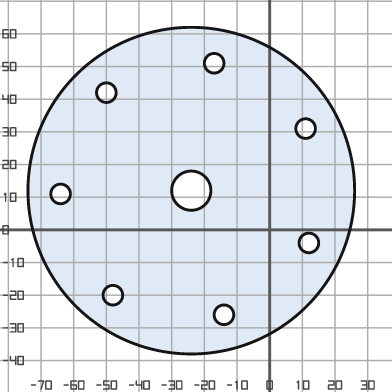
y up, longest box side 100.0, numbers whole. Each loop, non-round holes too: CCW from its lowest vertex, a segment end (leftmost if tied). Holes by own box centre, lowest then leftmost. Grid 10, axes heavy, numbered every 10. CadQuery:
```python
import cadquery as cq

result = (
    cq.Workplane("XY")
    .moveTo(-24.0, 12.0)
    .circle(50.0)
    .moveTo(-14.0, -26.0)
    .circle(3.0)
    .moveTo(-48.0, -20.0)
    .circle(3.0)
    .moveTo(12.0, -4.0)
    .circle(3.0)
    .moveTo(-64.0, 11.0)
    .circle(3.0)
    .moveTo(-24.0, 12.0)
    .circle(6.0)
    .moveTo(11.0, 31.0)
    .circle(3.0)
    .moveTo(-50.0, 42.0)
    .circle(3.0)
    .moveTo(-17.0, 51.0)
    .circle(3.0)
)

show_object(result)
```